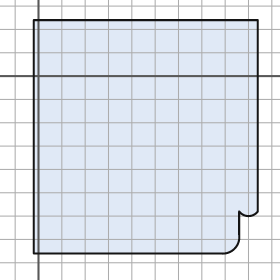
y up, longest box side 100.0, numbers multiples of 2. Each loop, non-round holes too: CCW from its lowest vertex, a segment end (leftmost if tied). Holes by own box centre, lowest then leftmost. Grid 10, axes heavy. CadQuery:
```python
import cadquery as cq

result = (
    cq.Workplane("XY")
    .moveTo(-2.0, -76.0)
    .lineTo(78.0, -76.0)
    .threePointArc((84.0, -74.0), (86.0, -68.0))
    .lineTo(86.0, -58.0)
    .threePointArc((90.0, -60.0), (94.0, -58.0))
    .lineTo(94.0, 24.0)
    .lineTo(-2.0, 24.0)
    .close()
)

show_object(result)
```